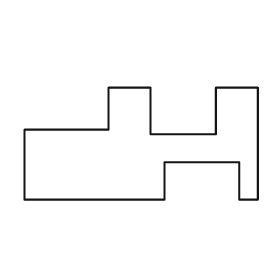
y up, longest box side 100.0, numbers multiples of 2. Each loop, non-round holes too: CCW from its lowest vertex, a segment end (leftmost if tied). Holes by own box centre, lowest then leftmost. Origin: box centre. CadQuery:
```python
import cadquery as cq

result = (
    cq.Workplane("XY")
    .moveTo(-50.0, -24.0)
    .lineTo(10.0, -24.0)
    .lineTo(10.0, -8.0)
    .lineTo(42.0, -8.0)
    .lineTo(42.0, -24.0)
    .lineTo(50.0, -24.0)
    .lineTo(50.0, 24.0)
    .lineTo(32.0, 24.0)
    .lineTo(32.0, 4.0)
    .lineTo(4.0, 4.0)
    .lineTo(4.0, 24.0)
    .lineTo(-14.0, 24.0)
    .lineTo(-14.0, 6.0)
    .lineTo(-50.0, 6.0)
    .close()
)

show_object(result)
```